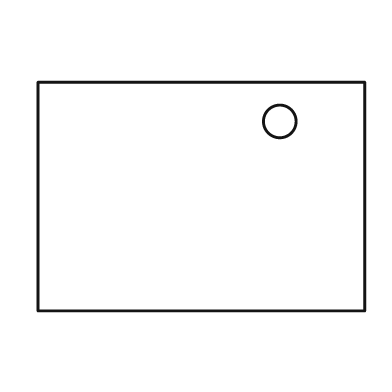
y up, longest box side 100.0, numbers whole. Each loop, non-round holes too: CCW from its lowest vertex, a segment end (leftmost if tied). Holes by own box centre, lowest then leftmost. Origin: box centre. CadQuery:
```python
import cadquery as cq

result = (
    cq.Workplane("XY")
    .moveTo(-50.0, -35.0)
    .lineTo(50.0, -35.0)
    .lineTo(50.0, 35.0)
    .lineTo(-50.0, 35.0)
    .close()
    .moveTo(24.0, 23.0)
    .circle(5.0)
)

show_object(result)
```